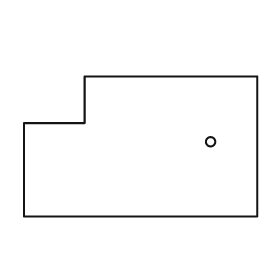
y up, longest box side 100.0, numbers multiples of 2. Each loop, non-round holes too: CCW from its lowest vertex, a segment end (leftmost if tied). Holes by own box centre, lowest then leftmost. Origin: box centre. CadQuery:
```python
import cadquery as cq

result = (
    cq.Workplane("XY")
    .moveTo(-50.0, -30.0)
    .lineTo(50.0, -30.0)
    .lineTo(50.0, 30.0)
    .lineTo(-24.0, 30.0)
    .lineTo(-24.0, 10.0)
    .lineTo(-50.0, 10.0)
    .close()
    .moveTo(30.0, 2.0)
    .circle(2.0)
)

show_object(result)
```